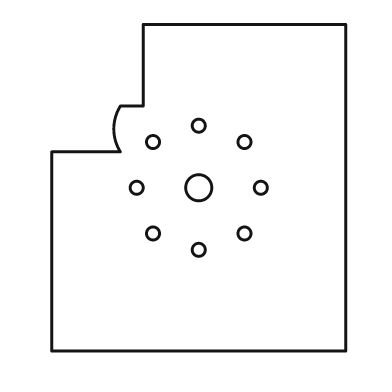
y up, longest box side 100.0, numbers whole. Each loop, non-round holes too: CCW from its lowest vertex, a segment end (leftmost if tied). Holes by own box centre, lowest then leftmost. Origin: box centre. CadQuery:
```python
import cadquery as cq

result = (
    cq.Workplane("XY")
    .moveTo(-45.0, -50.0)
    .lineTo(45.0, -50.0)
    .lineTo(45.0, 50.0)
    .lineTo(-17.0, 50.0)
    .lineTo(-17.0, 25.0)
    .lineTo(-24.0, 25.0)
    .threePointArc((-26.0, 18.0), (-24.0, 11.0))
    .lineTo(-45.0, 11.0)
    .close()
    .moveTo(0.0, -19.0)
    .circle(2.0)
    .moveTo(-14.0, -14.0)
    .circle(2.0)
    .moveTo(14.0, -14.0)
    .circle(2.0)
    .moveTo(-19.0, 0.0)
    .circle(2.0)
    .moveTo(0.0, 0.0)
    .circle(4.0)
    .moveTo(19.0, 0.0)
    .circle(2.0)
    .moveTo(-14.0, 14.0)
    .circle(2.0)
    .moveTo(14.0, 14.0)
    .circle(2.0)
    .moveTo(0.0, 19.0)
    .circle(2.0)
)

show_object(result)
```